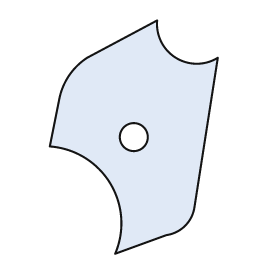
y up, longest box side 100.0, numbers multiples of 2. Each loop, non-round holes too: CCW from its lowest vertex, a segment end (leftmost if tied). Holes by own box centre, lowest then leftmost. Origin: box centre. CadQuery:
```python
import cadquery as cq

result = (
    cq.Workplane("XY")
    .moveTo(-8.0, -50.0)
    .lineTo(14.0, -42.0)
    .threePointArc((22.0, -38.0), (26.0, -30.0))
    .lineTo(36.0, 34.0)
    .threePointArc((18.0, 34.0), (10.0, 50.0))
    .lineTo(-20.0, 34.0)
    .threePointArc((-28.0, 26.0), (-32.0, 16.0))
    .lineTo(-36.0, -4.0)
    .threePointArc((-10.0, -20.0), (-8.0, -50.0))
    .close()
    .moveTo(0.0, 0.0)
    .circle(6.0)
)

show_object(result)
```